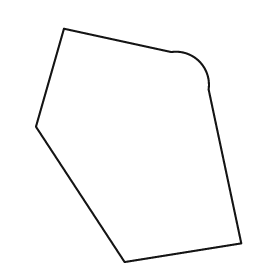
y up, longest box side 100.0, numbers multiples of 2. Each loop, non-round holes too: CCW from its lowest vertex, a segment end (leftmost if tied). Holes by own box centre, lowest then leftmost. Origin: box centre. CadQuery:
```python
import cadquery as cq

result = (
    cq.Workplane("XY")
    .moveTo(-6.0, -50.0)
    .lineTo(44.0, -42.0)
    .lineTo(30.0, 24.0)
    .threePointArc((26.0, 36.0), (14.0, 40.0))
    .lineTo(-32.0, 50.0)
    .lineTo(-44.0, 8.0)
    .close()
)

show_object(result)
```